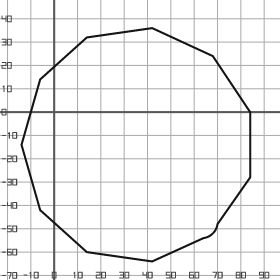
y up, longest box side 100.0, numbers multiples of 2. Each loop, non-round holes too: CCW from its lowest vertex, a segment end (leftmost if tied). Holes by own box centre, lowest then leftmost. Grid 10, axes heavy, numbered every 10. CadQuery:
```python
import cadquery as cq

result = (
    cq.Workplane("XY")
    .moveTo(42.0, -64.0)
    .lineTo(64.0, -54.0)
    .threePointArc((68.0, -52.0), (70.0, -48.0))
    .lineTo(84.0, -28.0)
    .lineTo(84.0, 0.0)
    .lineTo(68.0, 24.0)
    .lineTo(42.0, 36.0)
    .lineTo(14.0, 32.0)
    .lineTo(-6.0, 14.0)
    .lineTo(-14.0, -14.0)
    .lineTo(-6.0, -42.0)
    .lineTo(14.0, -60.0)
    .close()
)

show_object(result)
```